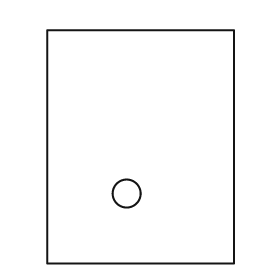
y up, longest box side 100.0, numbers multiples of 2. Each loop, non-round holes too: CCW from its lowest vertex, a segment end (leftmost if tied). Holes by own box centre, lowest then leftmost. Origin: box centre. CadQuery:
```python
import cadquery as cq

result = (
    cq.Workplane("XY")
    .moveTo(-40.0, -50.0)
    .lineTo(40.0, -50.0)
    .lineTo(40.0, 50.0)
    .lineTo(-40.0, 50.0)
    .close()
    .moveTo(-6.0, -20.0)
    .circle(6.0)
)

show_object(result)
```